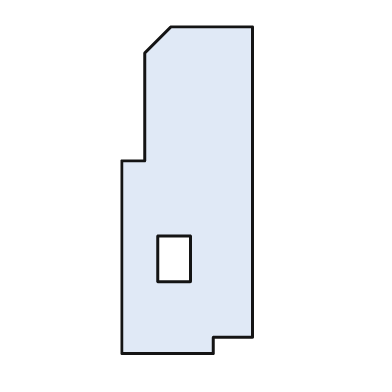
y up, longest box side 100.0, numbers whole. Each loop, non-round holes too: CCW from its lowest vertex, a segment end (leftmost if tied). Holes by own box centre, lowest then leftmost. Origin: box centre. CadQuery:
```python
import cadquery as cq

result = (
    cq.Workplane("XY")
    .moveTo(-20.0, -50.0)
    .lineTo(8.0, -50.0)
    .lineTo(8.0, -45.0)
    .lineTo(20.0, -45.0)
    .lineTo(20.0, 50.0)
    .lineTo(-5.0, 50.0)
    .lineTo(-13.0, 42.0)
    .lineTo(-13.0, 9.0)
    .lineTo(-20.0, 9.0)
    .close()
    .moveTo(-9.0, -28.0)
    .lineTo(1.0, -28.0)
    .lineTo(1.0, -14.0)
    .lineTo(-9.0, -14.0)
    .close()
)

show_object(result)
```